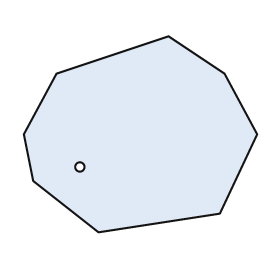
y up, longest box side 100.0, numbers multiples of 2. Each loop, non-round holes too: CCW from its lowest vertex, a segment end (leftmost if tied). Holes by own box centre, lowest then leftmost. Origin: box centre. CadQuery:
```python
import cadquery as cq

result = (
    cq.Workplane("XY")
    .moveTo(-18.0, -42.0)
    .lineTo(34.0, -34.0)
    .lineTo(50.0, 0.0)
    .lineTo(36.0, 26.0)
    .lineTo(12.0, 42.0)
    .lineTo(-36.0, 26.0)
    .lineTo(-50.0, 0.0)
    .lineTo(-46.0, -20.0)
    .close()
    .moveTo(-26.0, -14.0)
    .circle(2.0)
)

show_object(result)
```